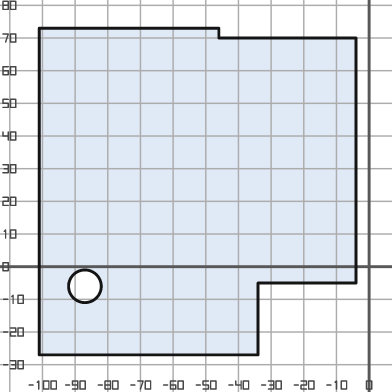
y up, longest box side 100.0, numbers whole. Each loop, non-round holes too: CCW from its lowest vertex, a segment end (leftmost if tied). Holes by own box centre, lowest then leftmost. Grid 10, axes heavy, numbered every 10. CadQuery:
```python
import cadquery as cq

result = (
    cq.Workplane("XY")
    .moveTo(-101.0, -27.0)
    .lineTo(-34.0, -27.0)
    .lineTo(-34.0, -5.0)
    .lineTo(-4.0, -5.0)
    .lineTo(-4.0, 70.0)
    .lineTo(-46.0, 70.0)
    .lineTo(-46.0, 73.0)
    .lineTo(-101.0, 73.0)
    .close()
    .moveTo(-87.0, -6.0)
    .circle(5.0)
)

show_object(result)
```